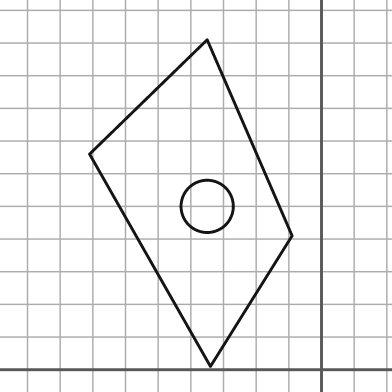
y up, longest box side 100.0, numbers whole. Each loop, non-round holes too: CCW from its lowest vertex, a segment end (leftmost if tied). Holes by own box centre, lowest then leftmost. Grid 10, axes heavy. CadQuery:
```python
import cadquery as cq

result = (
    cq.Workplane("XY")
    .moveTo(-34.0, 1.0)
    .lineTo(-9.0, 41.0)
    .lineTo(-35.0, 101.0)
    .lineTo(-71.0, 66.0)
    .close()
    .moveTo(-35.0, 50.0)
    .circle(8.0)
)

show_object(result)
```